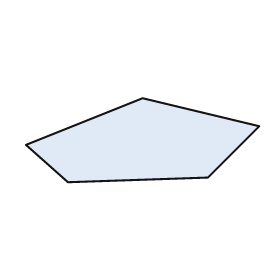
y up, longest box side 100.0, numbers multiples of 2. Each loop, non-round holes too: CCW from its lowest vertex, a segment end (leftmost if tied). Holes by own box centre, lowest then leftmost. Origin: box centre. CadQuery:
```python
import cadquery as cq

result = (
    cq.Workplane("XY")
    .moveTo(-32.0, -18.0)
    .lineTo(28.0, -16.0)
    .lineTo(50.0, 6.0)
    .lineTo(0.0, 18.0)
    .lineTo(-50.0, -2.0)
    .close()
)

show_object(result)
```